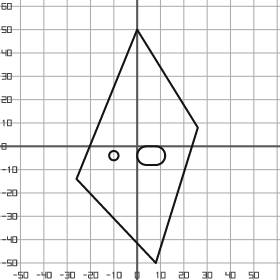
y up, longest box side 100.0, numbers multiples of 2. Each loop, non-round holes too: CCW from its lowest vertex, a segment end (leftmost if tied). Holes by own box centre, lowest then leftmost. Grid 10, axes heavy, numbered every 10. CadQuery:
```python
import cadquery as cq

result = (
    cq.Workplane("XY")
    .moveTo(8.0, -50.0)
    .lineTo(26.0, 8.0)
    .lineTo(0.0, 50.0)
    .lineTo(-26.0, -14.0)
    .close()
    .moveTo(-10.0, -4.0)
    .circle(2.0)
    .moveTo(4.0, -8.0)
    .lineTo(8.0, -8.0)
    .threePointArc((12.0, -4.0), (8.0, 0.0))
    .lineTo(4.0, 0.0)
    .threePointArc((0.0, -4.0), (4.0, -8.0))
    .close()
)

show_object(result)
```